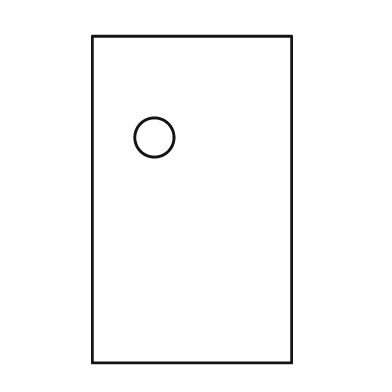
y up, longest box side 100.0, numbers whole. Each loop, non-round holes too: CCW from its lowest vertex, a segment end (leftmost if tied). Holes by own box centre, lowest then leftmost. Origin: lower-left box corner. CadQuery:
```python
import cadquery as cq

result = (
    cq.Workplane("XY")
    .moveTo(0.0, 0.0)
    .lineTo(61.0, 0.0)
    .lineTo(61.0, 100.0)
    .lineTo(0.0, 100.0)
    .close()
    .moveTo(19.0, 69.0)
    .circle(6.0)
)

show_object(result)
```